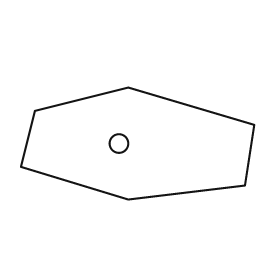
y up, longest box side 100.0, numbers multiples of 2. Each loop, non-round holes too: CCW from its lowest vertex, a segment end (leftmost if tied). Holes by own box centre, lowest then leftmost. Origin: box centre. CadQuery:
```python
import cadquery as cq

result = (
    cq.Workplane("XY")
    .moveTo(-4.0, -24.0)
    .lineTo(46.0, -18.0)
    .lineTo(50.0, 8.0)
    .lineTo(-4.0, 24.0)
    .lineTo(-44.0, 14.0)
    .lineTo(-50.0, -10.0)
    .close()
    .moveTo(-8.0, 0.0)
    .circle(4.0)
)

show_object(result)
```